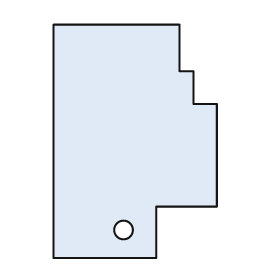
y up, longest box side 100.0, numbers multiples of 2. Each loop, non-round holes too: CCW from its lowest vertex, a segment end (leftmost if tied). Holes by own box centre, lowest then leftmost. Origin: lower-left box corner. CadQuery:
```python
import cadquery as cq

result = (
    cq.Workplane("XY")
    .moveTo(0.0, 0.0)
    .lineTo(44.0, 0.0)
    .lineTo(44.0, 22.0)
    .lineTo(70.0, 22.0)
    .lineTo(70.0, 66.0)
    .lineTo(60.0, 66.0)
    .lineTo(60.0, 80.0)
    .lineTo(54.0, 80.0)
    .lineTo(54.0, 100.0)
    .lineTo(0.0, 100.0)
    .close()
    .moveTo(30.0, 12.0)
    .circle(4.0)
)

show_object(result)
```